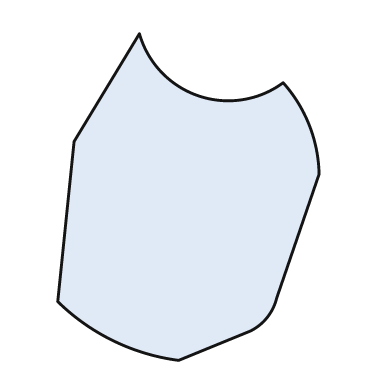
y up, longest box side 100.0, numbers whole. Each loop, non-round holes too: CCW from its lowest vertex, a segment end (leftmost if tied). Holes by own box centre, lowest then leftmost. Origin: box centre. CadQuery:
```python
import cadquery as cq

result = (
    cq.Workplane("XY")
    .moveTo(-3.0, -50.0)
    .lineTo(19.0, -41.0)
    .threePointArc((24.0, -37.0), (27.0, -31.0))
    .lineTo(40.0, 7.0)
    .threePointArc((37.0, 22.0), (29.0, 35.0))
    .threePointArc((3.0, 31.0), (-15.0, 50.0))
    .lineTo(-35.0, 17.0)
    .lineTo(-40.0, -32.0)
    .threePointArc((-23.0, -44.0), (-3.0, -50.0))
    .close()
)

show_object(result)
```